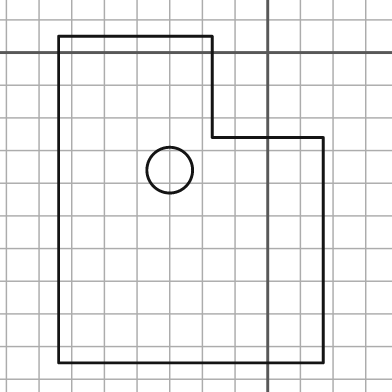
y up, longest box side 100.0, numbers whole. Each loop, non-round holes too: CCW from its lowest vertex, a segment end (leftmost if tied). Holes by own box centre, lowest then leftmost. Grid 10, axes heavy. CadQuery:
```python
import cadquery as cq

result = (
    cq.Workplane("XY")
    .moveTo(-64.0, -95.0)
    .lineTo(17.0, -95.0)
    .lineTo(17.0, -26.0)
    .lineTo(-17.0, -26.0)
    .lineTo(-17.0, 5.0)
    .lineTo(-64.0, 5.0)
    .close()
    .moveTo(-30.0, -36.0)
    .circle(7.0)
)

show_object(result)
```